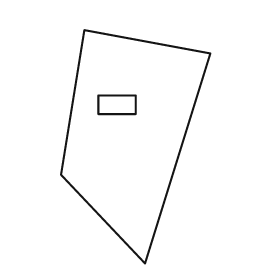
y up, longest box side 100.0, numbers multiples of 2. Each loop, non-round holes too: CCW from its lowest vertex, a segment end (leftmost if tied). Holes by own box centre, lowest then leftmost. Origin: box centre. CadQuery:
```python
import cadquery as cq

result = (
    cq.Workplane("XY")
    .moveTo(4.0, -50.0)
    .lineTo(32.0, 40.0)
    .lineTo(-22.0, 50.0)
    .lineTo(-32.0, -12.0)
    .close()
    .moveTo(-16.0, 14.0)
    .lineTo(0.0, 14.0)
    .lineTo(0.0, 22.0)
    .lineTo(-16.0, 22.0)
    .close()
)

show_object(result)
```